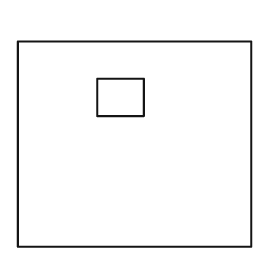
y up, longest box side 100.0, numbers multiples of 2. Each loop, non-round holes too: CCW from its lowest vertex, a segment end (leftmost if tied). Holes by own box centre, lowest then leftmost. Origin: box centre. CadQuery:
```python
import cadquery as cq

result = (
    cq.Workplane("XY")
    .moveTo(-50.0, -44.0)
    .lineTo(50.0, -44.0)
    .lineTo(50.0, 44.0)
    .lineTo(-50.0, 44.0)
    .close()
    .moveTo(-16.0, 12.0)
    .lineTo(4.0, 12.0)
    .lineTo(4.0, 28.0)
    .lineTo(-16.0, 28.0)
    .close()
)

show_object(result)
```